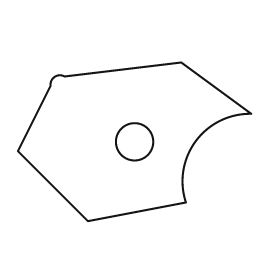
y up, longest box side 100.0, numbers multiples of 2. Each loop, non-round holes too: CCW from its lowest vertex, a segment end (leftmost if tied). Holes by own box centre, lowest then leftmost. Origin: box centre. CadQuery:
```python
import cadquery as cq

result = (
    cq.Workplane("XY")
    .moveTo(-20.0, -34.0)
    .lineTo(22.0, -26.0)
    .threePointArc((26.0, 0.0), (50.0, 12.0))
    .lineTo(20.0, 34.0)
    .lineTo(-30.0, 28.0)
    .threePointArc((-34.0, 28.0), (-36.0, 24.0))
    .lineTo(-50.0, -4.0)
    .close()
    .moveTo(0.0, 0.0)
    .circle(8.0)
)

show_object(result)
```